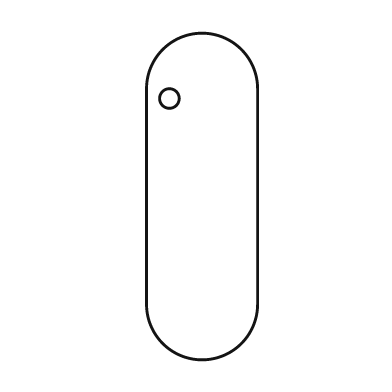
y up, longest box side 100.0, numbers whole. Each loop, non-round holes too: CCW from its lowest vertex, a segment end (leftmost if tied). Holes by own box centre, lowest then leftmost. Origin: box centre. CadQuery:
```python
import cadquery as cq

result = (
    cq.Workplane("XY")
    .moveTo(-17.0, -33.0)
    .threePointArc((0.0, -50.0), (17.0, -33.0))
    .lineTo(17.0, 33.0)
    .threePointArc((0.0, 50.0), (-17.0, 33.0))
    .close()
    .moveTo(-10.0, 30.0)
    .circle(3.0)
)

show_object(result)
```